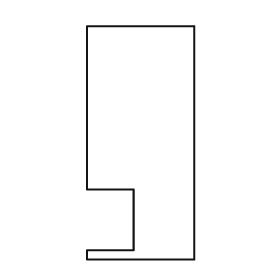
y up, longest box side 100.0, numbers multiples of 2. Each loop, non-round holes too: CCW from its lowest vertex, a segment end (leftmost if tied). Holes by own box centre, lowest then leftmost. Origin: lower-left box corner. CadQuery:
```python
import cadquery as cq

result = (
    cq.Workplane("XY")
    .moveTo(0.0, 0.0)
    .lineTo(46.0, 0.0)
    .lineTo(46.0, 100.0)
    .lineTo(0.0, 100.0)
    .lineTo(0.0, 30.0)
    .lineTo(20.0, 30.0)
    .lineTo(20.0, 4.0)
    .lineTo(0.0, 4.0)
    .close()
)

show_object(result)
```